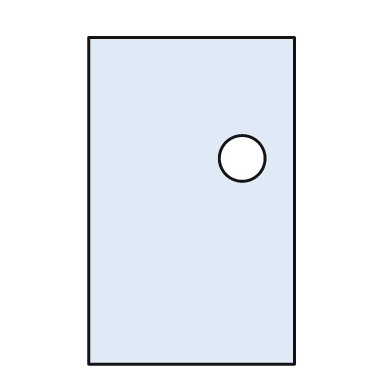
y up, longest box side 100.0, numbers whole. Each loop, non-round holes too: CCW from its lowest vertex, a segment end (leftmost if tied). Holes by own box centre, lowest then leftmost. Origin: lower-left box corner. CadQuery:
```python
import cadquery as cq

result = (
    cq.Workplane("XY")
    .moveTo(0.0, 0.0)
    .lineTo(63.0, 0.0)
    .lineTo(63.0, 100.0)
    .lineTo(0.0, 100.0)
    .close()
    .moveTo(47.0, 63.0)
    .circle(7.0)
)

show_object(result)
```